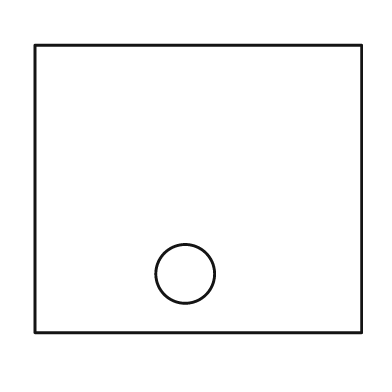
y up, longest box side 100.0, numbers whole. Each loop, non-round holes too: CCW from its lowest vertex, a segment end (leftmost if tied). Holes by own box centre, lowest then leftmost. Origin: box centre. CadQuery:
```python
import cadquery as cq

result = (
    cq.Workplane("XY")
    .moveTo(-50.0, -44.0)
    .lineTo(50.0, -44.0)
    .lineTo(50.0, 44.0)
    .lineTo(-50.0, 44.0)
    .close()
    .moveTo(-4.0, -26.0)
    .circle(9.0)
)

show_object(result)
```